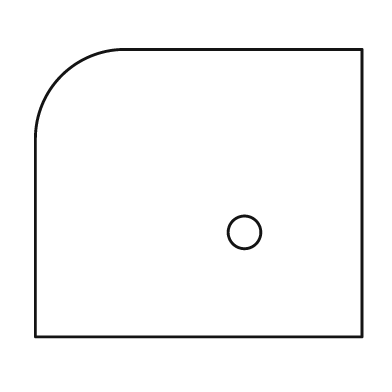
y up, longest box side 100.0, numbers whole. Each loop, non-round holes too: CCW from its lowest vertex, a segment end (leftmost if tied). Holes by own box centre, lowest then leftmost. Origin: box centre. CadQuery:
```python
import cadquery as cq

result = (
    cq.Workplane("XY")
    .moveTo(-50.0, -44.0)
    .lineTo(50.0, -44.0)
    .lineTo(50.0, 44.0)
    .lineTo(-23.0, 44.0)
    .threePointArc((-42.0, 36.0), (-50.0, 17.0))
    .close()
    .moveTo(14.0, -12.0)
    .circle(5.0)
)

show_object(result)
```